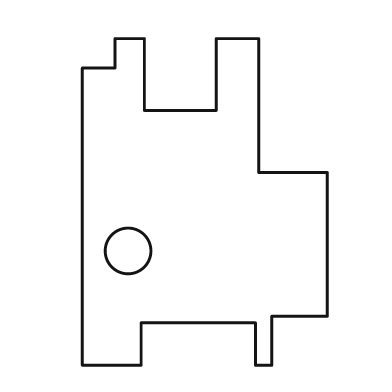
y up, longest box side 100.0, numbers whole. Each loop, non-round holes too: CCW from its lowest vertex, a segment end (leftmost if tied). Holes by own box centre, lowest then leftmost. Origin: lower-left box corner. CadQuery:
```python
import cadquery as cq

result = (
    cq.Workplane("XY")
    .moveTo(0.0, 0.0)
    .lineTo(18.0, 0.0)
    .lineTo(18.0, 13.0)
    .lineTo(53.0, 13.0)
    .lineTo(53.0, 0.0)
    .lineTo(58.0, 0.0)
    .lineTo(58.0, 15.0)
    .lineTo(75.0, 15.0)
    .lineTo(75.0, 59.0)
    .lineTo(54.0, 59.0)
    .lineTo(54.0, 100.0)
    .lineTo(41.0, 100.0)
    .lineTo(41.0, 78.0)
    .lineTo(19.0, 78.0)
    .lineTo(19.0, 100.0)
    .lineTo(10.0, 100.0)
    .lineTo(10.0, 91.0)
    .lineTo(0.0, 91.0)
    .close()
    .moveTo(14.0, 35.0)
    .circle(7.0)
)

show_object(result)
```